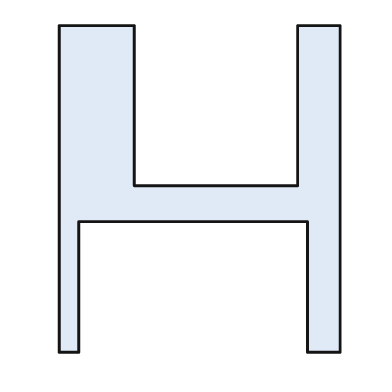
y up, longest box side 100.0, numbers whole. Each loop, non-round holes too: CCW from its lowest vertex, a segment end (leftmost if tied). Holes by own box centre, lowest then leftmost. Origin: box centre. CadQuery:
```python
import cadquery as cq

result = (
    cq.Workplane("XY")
    .moveTo(-43.0, -50.0)
    .lineTo(-37.0, -50.0)
    .lineTo(-37.0, -10.0)
    .lineTo(33.0, -10.0)
    .lineTo(33.0, -50.0)
    .lineTo(43.0, -50.0)
    .lineTo(43.0, 50.0)
    .lineTo(30.0, 50.0)
    .lineTo(30.0, 1.0)
    .lineTo(-20.0, 1.0)
    .lineTo(-20.0, 50.0)
    .lineTo(-43.0, 50.0)
    .close()
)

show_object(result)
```